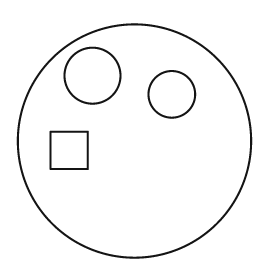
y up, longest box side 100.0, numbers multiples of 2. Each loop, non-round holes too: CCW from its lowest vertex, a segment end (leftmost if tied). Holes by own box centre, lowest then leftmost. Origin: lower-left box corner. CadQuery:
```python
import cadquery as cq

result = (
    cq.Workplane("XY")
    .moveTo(50.0, 50.0)
    .circle(50.0)
    .moveTo(14.0, 38.0)
    .lineTo(30.0, 38.0)
    .lineTo(30.0, 54.0)
    .lineTo(14.0, 54.0)
    .close()
    .moveTo(66.0, 70.0)
    .circle(10.0)
    .moveTo(32.0, 78.0)
    .circle(12.0)
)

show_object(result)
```